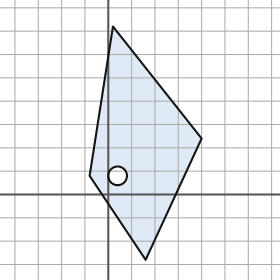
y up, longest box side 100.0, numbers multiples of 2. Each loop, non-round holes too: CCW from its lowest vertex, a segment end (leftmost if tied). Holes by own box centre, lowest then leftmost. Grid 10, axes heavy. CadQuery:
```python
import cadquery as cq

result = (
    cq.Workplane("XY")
    .moveTo(16.0, -28.0)
    .lineTo(40.0, 24.0)
    .lineTo(2.0, 72.0)
    .lineTo(-8.0, 8.0)
    .close()
    .moveTo(4.0, 8.0)
    .circle(4.0)
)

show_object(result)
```